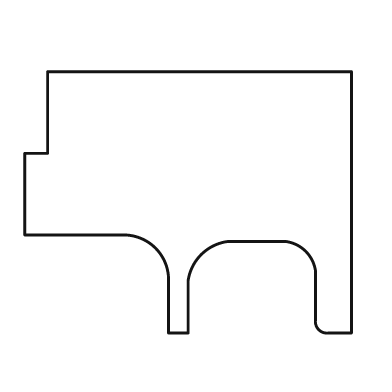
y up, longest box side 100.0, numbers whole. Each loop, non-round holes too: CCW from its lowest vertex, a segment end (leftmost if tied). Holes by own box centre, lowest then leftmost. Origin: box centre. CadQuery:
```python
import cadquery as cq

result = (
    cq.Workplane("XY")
    .moveTo(-6.0, -40.0)
    .lineTo(0.0, -40.0)
    .lineTo(0.0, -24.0)
    .threePointArc((4.0, -16.0), (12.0, -12.0))
    .lineTo(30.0, -12.0)
    .threePointArc((36.0, -15.0), (39.0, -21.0))
    .lineTo(39.0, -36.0)
    .threePointArc((40.0, -39.0), (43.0, -40.0))
    .lineTo(50.0, -40.0)
    .lineTo(50.0, 40.0)
    .lineTo(-43.0, 40.0)
    .lineTo(-43.0, 15.0)
    .lineTo(-50.0, 15.0)
    .lineTo(-50.0, -10.0)
    .lineTo(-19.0, -10.0)
    .threePointArc((-10.0, -14.0), (-6.0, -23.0))
    .close()
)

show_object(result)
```